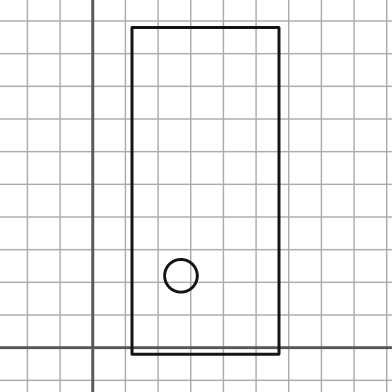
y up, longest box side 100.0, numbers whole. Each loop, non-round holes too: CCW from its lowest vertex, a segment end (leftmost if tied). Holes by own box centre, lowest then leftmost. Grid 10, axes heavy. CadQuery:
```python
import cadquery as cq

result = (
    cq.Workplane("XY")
    .moveTo(12.0, -2.0)
    .lineTo(57.0, -2.0)
    .lineTo(57.0, 98.0)
    .lineTo(12.0, 98.0)
    .close()
    .moveTo(27.0, 22.0)
    .circle(5.0)
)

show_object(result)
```